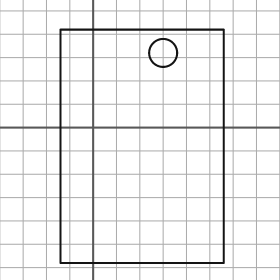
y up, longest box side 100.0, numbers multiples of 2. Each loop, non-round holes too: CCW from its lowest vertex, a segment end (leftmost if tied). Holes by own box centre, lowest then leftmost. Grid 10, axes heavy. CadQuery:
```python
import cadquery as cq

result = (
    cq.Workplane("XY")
    .moveTo(-14.0, -58.0)
    .lineTo(56.0, -58.0)
    .lineTo(56.0, 42.0)
    .lineTo(-14.0, 42.0)
    .close()
    .moveTo(30.0, 32.0)
    .circle(6.0)
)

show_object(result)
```